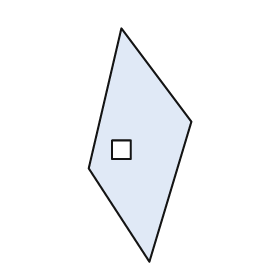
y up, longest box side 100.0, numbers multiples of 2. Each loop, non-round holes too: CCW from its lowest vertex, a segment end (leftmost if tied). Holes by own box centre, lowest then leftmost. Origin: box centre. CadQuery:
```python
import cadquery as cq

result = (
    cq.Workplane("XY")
    .moveTo(4.0, -50.0)
    .lineTo(22.0, 10.0)
    .lineTo(-8.0, 50.0)
    .lineTo(-22.0, -10.0)
    .close()
    .moveTo(-12.0, -6.0)
    .lineTo(-4.0, -6.0)
    .lineTo(-4.0, 2.0)
    .lineTo(-12.0, 2.0)
    .close()
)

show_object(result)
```